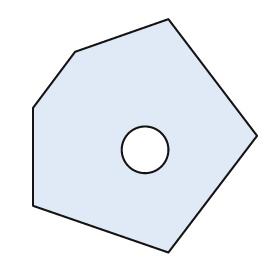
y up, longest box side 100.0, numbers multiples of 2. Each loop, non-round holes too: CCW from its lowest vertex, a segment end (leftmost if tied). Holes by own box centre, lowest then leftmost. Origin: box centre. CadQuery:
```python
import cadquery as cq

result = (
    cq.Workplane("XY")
    .moveTo(10.0, -50.0)
    .lineTo(48.0, 0.0)
    .lineTo(10.0, 50.0)
    .lineTo(-30.0, 36.0)
    .lineTo(-48.0, 12.0)
    .lineTo(-48.0, -30.0)
    .close()
    .moveTo(0.0, -6.0)
    .circle(10.0)
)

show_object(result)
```